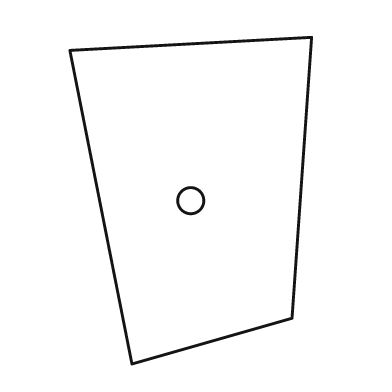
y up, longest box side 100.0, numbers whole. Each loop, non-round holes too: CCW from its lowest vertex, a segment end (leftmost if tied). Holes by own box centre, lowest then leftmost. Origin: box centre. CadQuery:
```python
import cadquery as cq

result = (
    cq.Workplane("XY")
    .moveTo(-18.0, -50.0)
    .lineTo(31.0, -36.0)
    .lineTo(37.0, 50.0)
    .lineTo(-37.0, 46.0)
    .close()
    .moveTo(0.0, 0.0)
    .circle(4.0)
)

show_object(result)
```